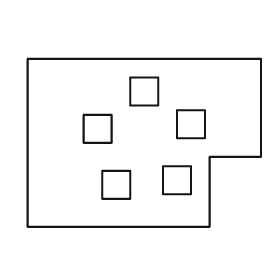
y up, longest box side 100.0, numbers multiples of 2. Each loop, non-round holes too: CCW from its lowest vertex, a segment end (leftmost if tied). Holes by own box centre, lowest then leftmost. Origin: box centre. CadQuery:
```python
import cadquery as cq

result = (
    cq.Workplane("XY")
    .moveTo(-50.0, -36.0)
    .lineTo(28.0, -36.0)
    .lineTo(28.0, -6.0)
    .lineTo(50.0, -6.0)
    .lineTo(50.0, 36.0)
    .lineTo(-50.0, 36.0)
    .close()
    .moveTo(-18.0, -24.0)
    .lineTo(-6.0, -24.0)
    .lineTo(-6.0, -12.0)
    .lineTo(-18.0, -12.0)
    .close()
    .moveTo(8.0, -22.0)
    .lineTo(20.0, -22.0)
    .lineTo(20.0, -10.0)
    .lineTo(8.0, -10.0)
    .close()
    .moveTo(-26.0, 0.0)
    .lineTo(-14.0, 0.0)
    .lineTo(-14.0, 12.0)
    .lineTo(-26.0, 12.0)
    .close()
    .moveTo(14.0, 2.0)
    .lineTo(26.0, 2.0)
    .lineTo(26.0, 14.0)
    .lineTo(14.0, 14.0)
    .close()
    .moveTo(-6.0, 16.0)
    .lineTo(6.0, 16.0)
    .lineTo(6.0, 28.0)
    .lineTo(-6.0, 28.0)
    .close()
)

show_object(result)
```